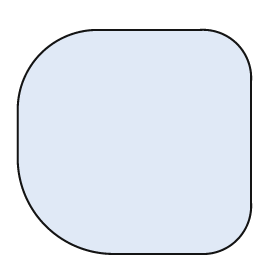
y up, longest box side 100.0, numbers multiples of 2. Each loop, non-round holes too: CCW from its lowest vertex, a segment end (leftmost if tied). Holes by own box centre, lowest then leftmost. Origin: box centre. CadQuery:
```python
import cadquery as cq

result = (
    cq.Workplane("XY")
    .moveTo(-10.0, -48.0)
    .lineTo(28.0, -48.0)
    .threePointArc((44.0, -42.0), (50.0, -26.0))
    .lineTo(50.0, 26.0)
    .threePointArc((44.0, 42.0), (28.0, 48.0))
    .lineTo(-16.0, 48.0)
    .threePointArc((-40.0, 38.0), (-50.0, 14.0))
    .lineTo(-50.0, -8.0)
    .threePointArc((-38.0, -36.0), (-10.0, -48.0))
    .close()
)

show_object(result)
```